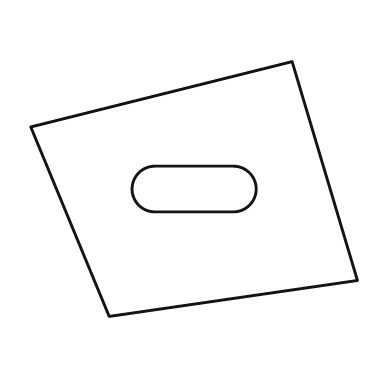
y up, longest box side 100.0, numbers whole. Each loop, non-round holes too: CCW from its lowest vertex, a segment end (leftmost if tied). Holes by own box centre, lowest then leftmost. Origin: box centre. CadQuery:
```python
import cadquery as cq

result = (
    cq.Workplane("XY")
    .moveTo(-26.0, -39.0)
    .lineTo(50.0, -28.0)
    .lineTo(30.0, 39.0)
    .lineTo(-50.0, 19.0)
    .close()
    .moveTo(-12.0, -7.0)
    .lineTo(12.0, -7.0)
    .threePointArc((19.0, 0.0), (12.0, 7.0))
    .lineTo(-12.0, 7.0)
    .threePointArc((-19.0, 0.0), (-12.0, -7.0))
    .close()
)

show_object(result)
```